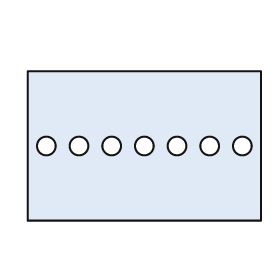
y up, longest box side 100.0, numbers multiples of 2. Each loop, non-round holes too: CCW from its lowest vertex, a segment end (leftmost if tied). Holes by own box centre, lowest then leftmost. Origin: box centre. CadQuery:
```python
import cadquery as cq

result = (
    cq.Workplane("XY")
    .moveTo(-50.0, -32.0)
    .lineTo(50.0, -32.0)
    .lineTo(50.0, 32.0)
    .lineTo(-50.0, 32.0)
    .close()
    .moveTo(-42.0, 0.0)
    .circle(4.0)
    .moveTo(-28.0, 0.0)
    .circle(4.0)
    .moveTo(-14.0, 0.0)
    .circle(4.0)
    .moveTo(0.0, 0.0)
    .circle(4.0)
    .moveTo(14.0, 0.0)
    .circle(4.0)
    .moveTo(28.0, 0.0)
    .circle(4.0)
    .moveTo(42.0, 0.0)
    .circle(4.0)
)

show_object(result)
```